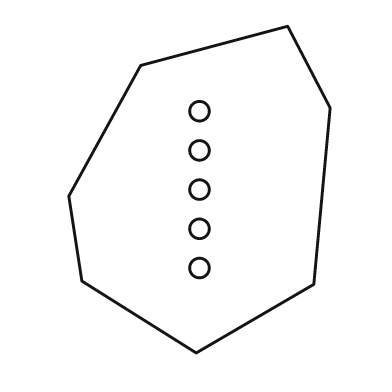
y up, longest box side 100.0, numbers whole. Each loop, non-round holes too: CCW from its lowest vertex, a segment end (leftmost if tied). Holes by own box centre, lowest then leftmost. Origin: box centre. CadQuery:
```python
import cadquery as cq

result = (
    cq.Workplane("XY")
    .moveTo(-1.0, -50.0)
    .lineTo(35.0, -29.0)
    .lineTo(40.0, 25.0)
    .lineTo(27.0, 50.0)
    .lineTo(-18.0, 38.0)
    .lineTo(-40.0, -2.0)
    .lineTo(-36.0, -28.0)
    .close()
    .moveTo(0.0, -24.0)
    .circle(3.0)
    .moveTo(0.0, -12.0)
    .circle(3.0)
    .moveTo(0.0, 0.0)
    .circle(3.0)
    .moveTo(0.0, 12.0)
    .circle(3.0)
    .moveTo(0.0, 24.0)
    .circle(3.0)
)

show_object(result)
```